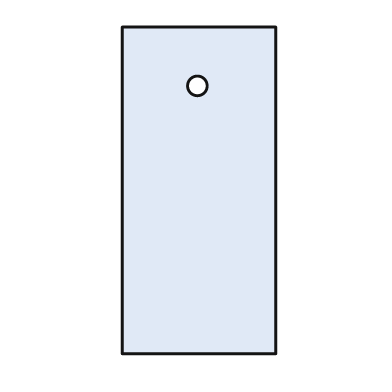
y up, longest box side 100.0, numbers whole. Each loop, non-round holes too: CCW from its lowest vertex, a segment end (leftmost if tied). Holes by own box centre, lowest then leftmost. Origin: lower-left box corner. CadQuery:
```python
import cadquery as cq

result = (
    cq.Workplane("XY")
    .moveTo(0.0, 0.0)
    .lineTo(47.0, 0.0)
    .lineTo(47.0, 100.0)
    .lineTo(0.0, 100.0)
    .close()
    .moveTo(23.0, 82.0)
    .circle(3.0)
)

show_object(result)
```